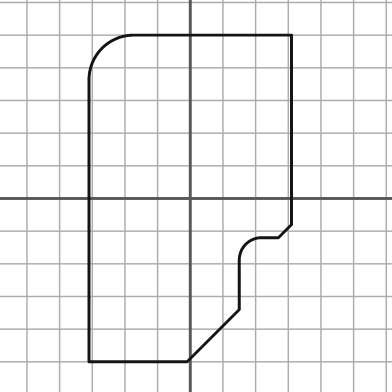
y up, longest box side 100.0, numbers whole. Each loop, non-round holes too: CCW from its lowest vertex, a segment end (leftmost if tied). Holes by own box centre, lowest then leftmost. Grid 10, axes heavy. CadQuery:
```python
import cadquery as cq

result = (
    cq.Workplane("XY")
    .moveTo(-31.0, -50.0)
    .lineTo(-1.0, -50.0)
    .lineTo(15.0, -34.0)
    .lineTo(15.0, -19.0)
    .threePointArc((17.0, -14.0), (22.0, -12.0))
    .lineTo(27.0, -12.0)
    .lineTo(31.0, -8.0)
    .lineTo(31.0, 50.0)
    .lineTo(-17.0, 50.0)
    .threePointArc((-27.0, 46.0), (-31.0, 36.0))
    .close()
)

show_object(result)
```